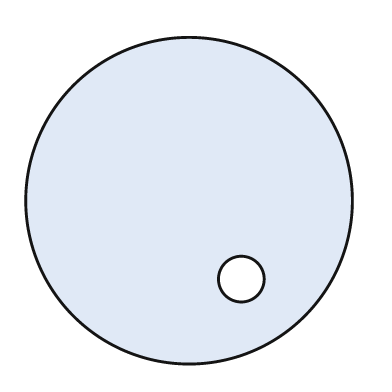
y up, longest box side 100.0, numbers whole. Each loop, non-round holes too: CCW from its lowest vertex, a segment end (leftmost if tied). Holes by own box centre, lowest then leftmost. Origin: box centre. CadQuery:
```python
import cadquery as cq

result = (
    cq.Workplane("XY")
    .moveTo(0.0, 0.0)
    .circle(50.0)
    .moveTo(16.0, -24.0)
    .circle(7.0)
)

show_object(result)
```